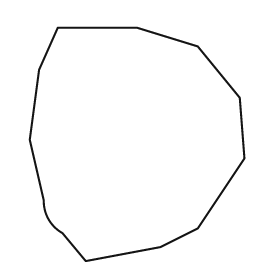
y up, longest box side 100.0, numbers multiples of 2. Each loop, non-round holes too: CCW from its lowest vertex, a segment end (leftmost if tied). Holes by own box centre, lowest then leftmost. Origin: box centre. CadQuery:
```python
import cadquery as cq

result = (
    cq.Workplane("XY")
    .moveTo(-22.0, -50.0)
    .lineTo(10.0, -44.0)
    .lineTo(26.0, -36.0)
    .lineTo(46.0, -6.0)
    .lineTo(44.0, 20.0)
    .lineTo(26.0, 42.0)
    .lineTo(0.0, 50.0)
    .lineTo(-34.0, 50.0)
    .lineTo(-42.0, 32.0)
    .lineTo(-46.0, 2.0)
    .lineTo(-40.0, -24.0)
    .threePointArc((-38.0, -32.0), (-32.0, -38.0))
    .close()
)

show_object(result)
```